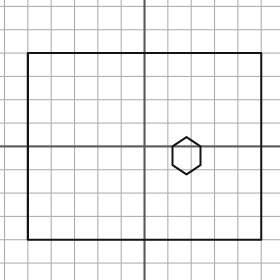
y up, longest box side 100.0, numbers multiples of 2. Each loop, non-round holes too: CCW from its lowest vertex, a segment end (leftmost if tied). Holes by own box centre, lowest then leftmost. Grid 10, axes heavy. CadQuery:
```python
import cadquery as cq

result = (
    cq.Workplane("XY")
    .moveTo(-50.0, -40.0)
    .lineTo(50.0, -40.0)
    .lineTo(50.0, 40.0)
    .lineTo(-50.0, 40.0)
    .close()
    .moveTo(18.0, -12.0)
    .lineTo(24.0, -8.0)
    .lineTo(24.0, 0.0)
    .lineTo(18.0, 4.0)
    .lineTo(12.0, 0.0)
    .lineTo(12.0, -8.0)
    .close()
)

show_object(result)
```